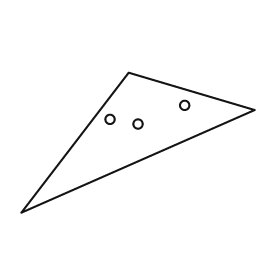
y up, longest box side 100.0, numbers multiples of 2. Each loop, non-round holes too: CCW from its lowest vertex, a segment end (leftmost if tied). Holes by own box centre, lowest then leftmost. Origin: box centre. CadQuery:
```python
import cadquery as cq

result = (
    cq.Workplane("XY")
    .moveTo(-50.0, -30.0)
    .lineTo(50.0, 14.0)
    .lineTo(-4.0, 30.0)
    .close()
    .moveTo(0.0, 8.0)
    .circle(2.0)
    .moveTo(-12.0, 10.0)
    .circle(2.0)
    .moveTo(20.0, 16.0)
    .circle(2.0)
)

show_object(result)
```